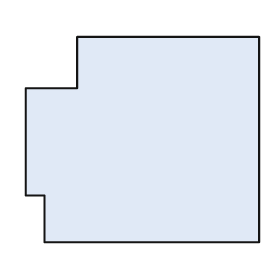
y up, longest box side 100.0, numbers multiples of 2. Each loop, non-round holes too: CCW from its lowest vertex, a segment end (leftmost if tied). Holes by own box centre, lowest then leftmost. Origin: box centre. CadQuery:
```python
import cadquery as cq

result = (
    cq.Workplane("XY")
    .moveTo(-42.0, -44.0)
    .lineTo(50.0, -44.0)
    .lineTo(50.0, 44.0)
    .lineTo(-28.0, 44.0)
    .lineTo(-28.0, 22.0)
    .lineTo(-50.0, 22.0)
    .lineTo(-50.0, -24.0)
    .lineTo(-42.0, -24.0)
    .close()
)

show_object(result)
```